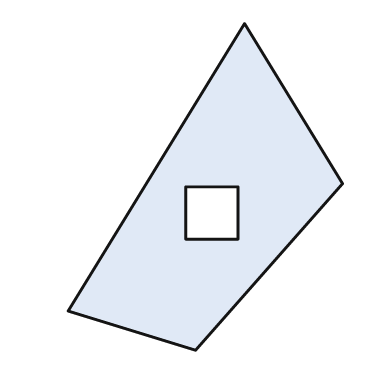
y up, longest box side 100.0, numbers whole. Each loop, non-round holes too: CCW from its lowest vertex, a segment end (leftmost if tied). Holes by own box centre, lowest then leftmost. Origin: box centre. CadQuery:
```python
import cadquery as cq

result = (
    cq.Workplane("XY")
    .moveTo(-3.0, -50.0)
    .lineTo(42.0, 1.0)
    .lineTo(12.0, 50.0)
    .lineTo(-42.0, -38.0)
    .close()
    .moveTo(-6.0, -16.0)
    .lineTo(10.0, -16.0)
    .lineTo(10.0, 0.0)
    .lineTo(-6.0, 0.0)
    .close()
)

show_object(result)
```